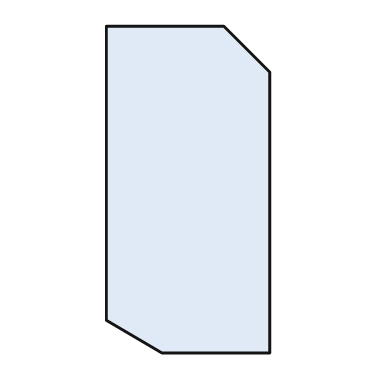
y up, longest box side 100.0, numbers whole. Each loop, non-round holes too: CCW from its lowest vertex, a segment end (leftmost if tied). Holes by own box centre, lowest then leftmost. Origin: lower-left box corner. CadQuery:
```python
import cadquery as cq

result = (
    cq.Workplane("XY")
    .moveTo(17.0, 0.0)
    .lineTo(50.0, 0.0)
    .lineTo(50.0, 86.0)
    .lineTo(36.0, 100.0)
    .lineTo(0.0, 100.0)
    .lineTo(0.0, 10.0)
    .close()
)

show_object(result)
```